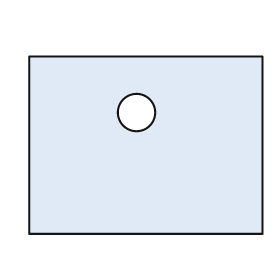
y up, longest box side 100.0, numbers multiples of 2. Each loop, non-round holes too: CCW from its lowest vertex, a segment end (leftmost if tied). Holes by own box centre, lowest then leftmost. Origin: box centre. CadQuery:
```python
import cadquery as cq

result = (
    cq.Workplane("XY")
    .moveTo(-50.0, -38.0)
    .lineTo(50.0, -38.0)
    .lineTo(50.0, 38.0)
    .lineTo(-50.0, 38.0)
    .close()
    .moveTo(-4.0, 14.0)
    .circle(8.0)
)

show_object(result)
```